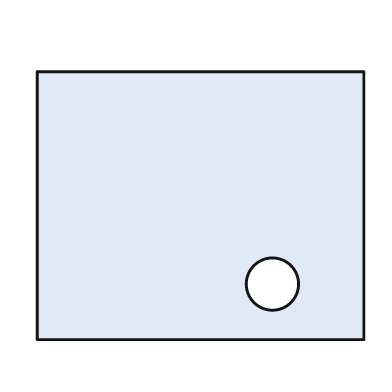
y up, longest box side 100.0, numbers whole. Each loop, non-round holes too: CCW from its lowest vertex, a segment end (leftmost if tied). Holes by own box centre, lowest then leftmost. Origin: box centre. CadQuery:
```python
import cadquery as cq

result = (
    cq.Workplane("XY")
    .moveTo(-50.0, -41.0)
    .lineTo(50.0, -41.0)
    .lineTo(50.0, 41.0)
    .lineTo(-50.0, 41.0)
    .close()
    .moveTo(22.0, -24.0)
    .circle(8.0)
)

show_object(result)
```